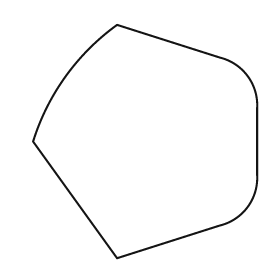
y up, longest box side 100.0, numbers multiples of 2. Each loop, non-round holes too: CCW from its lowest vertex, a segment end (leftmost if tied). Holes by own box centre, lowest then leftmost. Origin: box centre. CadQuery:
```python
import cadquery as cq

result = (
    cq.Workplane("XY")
    .moveTo(-12.0, -50.0)
    .lineTo(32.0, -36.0)
    .threePointArc((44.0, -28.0), (48.0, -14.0))
    .lineTo(48.0, 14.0)
    .threePointArc((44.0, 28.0), (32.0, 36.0))
    .lineTo(-12.0, 50.0)
    .threePointArc((-34.0, 28.0), (-48.0, 0.0))
    .close()
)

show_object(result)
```